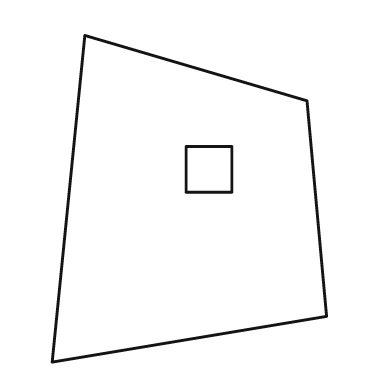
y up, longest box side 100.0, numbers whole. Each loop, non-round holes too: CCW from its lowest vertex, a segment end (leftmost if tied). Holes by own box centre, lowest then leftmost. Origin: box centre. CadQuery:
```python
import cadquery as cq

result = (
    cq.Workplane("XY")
    .moveTo(-42.0, -50.0)
    .lineTo(42.0, -36.0)
    .lineTo(36.0, 30.0)
    .lineTo(-32.0, 50.0)
    .close()
    .moveTo(-1.0, 2.0)
    .lineTo(13.0, 2.0)
    .lineTo(13.0, 16.0)
    .lineTo(-1.0, 16.0)
    .close()
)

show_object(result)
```